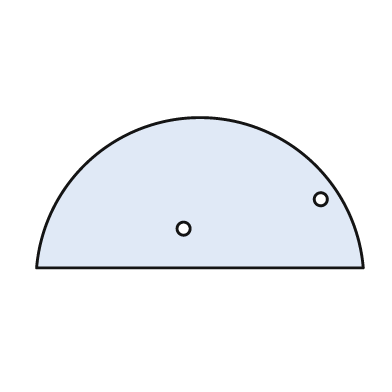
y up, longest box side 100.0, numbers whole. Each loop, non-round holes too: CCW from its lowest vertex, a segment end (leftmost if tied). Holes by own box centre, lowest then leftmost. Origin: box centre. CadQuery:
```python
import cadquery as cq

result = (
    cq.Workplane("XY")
    .moveTo(-50.0, -23.0)
    .lineTo(50.0, -23.0)
    .threePointArc((0.0, 23.0), (-50.0, -23.0))
    .close()
    .moveTo(-5.0, -11.0)
    .circle(2.0)
    .moveTo(37.0, -2.0)
    .circle(2.0)
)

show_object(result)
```